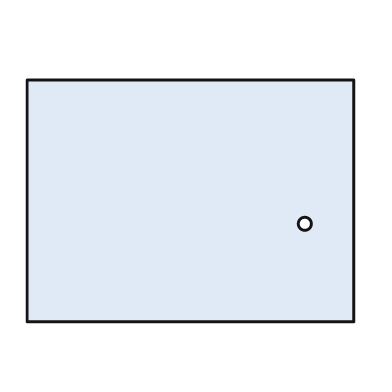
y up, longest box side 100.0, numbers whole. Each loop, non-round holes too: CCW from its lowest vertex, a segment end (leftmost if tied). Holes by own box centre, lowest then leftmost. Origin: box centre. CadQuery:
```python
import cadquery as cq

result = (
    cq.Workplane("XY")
    .moveTo(-50.0, -37.0)
    .lineTo(50.0, -37.0)
    .lineTo(50.0, 37.0)
    .lineTo(-50.0, 37.0)
    .close()
    .moveTo(35.0, -7.0)
    .circle(2.0)
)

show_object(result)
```